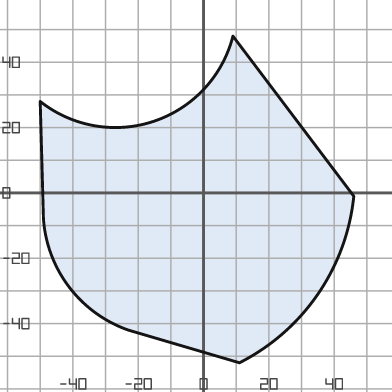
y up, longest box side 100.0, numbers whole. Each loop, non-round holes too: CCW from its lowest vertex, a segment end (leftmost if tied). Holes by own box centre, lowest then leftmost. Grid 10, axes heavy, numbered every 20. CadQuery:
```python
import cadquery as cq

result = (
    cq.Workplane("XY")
    .moveTo(11.0, -52.0)
    .threePointArc((35.0, -31.0), (46.0, -1.0))
    .lineTo(9.0, 48.0)
    .threePointArc((-15.0, 22.0), (-50.0, 28.0))
    .lineTo(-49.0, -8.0)
    .threePointArc((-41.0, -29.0), (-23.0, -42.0))
    .close()
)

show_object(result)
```